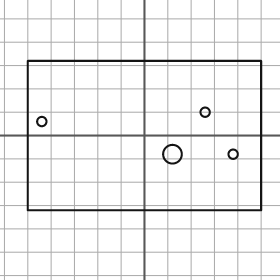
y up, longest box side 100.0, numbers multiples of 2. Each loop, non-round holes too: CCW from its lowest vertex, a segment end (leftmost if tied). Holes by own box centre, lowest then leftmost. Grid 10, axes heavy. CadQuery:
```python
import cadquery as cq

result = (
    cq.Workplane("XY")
    .moveTo(-50.0, -32.0)
    .lineTo(50.0, -32.0)
    .lineTo(50.0, 32.0)
    .lineTo(-50.0, 32.0)
    .close()
    .moveTo(12.0, -8.0)
    .circle(4.0)
    .moveTo(38.0, -8.0)
    .circle(2.0)
    .moveTo(-44.0, 6.0)
    .circle(2.0)
    .moveTo(26.0, 10.0)
    .circle(2.0)
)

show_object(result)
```